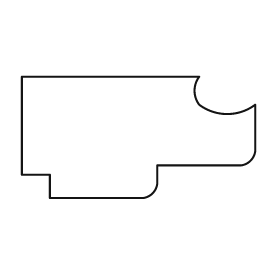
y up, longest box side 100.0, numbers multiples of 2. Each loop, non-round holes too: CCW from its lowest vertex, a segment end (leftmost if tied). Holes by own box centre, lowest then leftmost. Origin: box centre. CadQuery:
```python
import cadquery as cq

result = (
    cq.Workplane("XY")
    .moveTo(-38.0, -26.0)
    .lineTo(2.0, -26.0)
    .threePointArc((6.0, -24.0), (8.0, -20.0))
    .lineTo(8.0, -12.0)
    .lineTo(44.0, -12.0)
    .threePointArc((48.0, -10.0), (50.0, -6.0))
    .lineTo(50.0, 14.0)
    .threePointArc((38.0, 10.0), (26.0, 14.0))
    .threePointArc((24.0, 20.0), (26.0, 26.0))
    .lineTo(-50.0, 26.0)
    .lineTo(-50.0, -16.0)
    .lineTo(-38.0, -16.0)
    .close()
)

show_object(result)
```